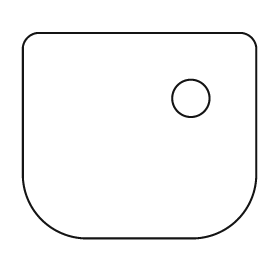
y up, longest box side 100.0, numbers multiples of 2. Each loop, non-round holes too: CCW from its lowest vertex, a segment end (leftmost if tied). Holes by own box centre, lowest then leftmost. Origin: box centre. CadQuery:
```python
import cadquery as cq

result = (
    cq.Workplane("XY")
    .moveTo(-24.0, -44.0)
    .lineTo(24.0, -44.0)
    .threePointArc((42.0, -36.0), (50.0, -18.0))
    .lineTo(50.0, 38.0)
    .threePointArc((48.0, 42.0), (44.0, 44.0))
    .lineTo(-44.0, 44.0)
    .threePointArc((-48.0, 42.0), (-50.0, 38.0))
    .lineTo(-50.0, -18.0)
    .threePointArc((-42.0, -36.0), (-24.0, -44.0))
    .close()
    .moveTo(22.0, 16.0)
    .circle(8.0)
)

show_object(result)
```